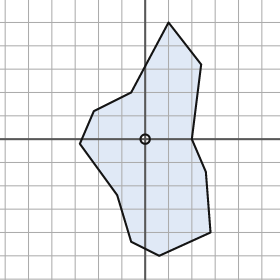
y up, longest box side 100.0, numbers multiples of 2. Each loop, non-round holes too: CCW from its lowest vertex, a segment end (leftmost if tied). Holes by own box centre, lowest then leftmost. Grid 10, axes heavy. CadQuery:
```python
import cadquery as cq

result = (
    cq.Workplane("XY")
    .moveTo(6.0, -50.0)
    .lineTo(28.0, -40.0)
    .lineTo(26.0, -14.0)
    .lineTo(20.0, 0.0)
    .lineTo(24.0, 32.0)
    .lineTo(10.0, 50.0)
    .lineTo(-6.0, 20.0)
    .lineTo(-22.0, 12.0)
    .lineTo(-28.0, -2.0)
    .lineTo(-12.0, -24.0)
    .lineTo(-6.0, -44.0)
    .close()
    .moveTo(0.0, 0.0)
    .circle(2.0)
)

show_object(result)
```